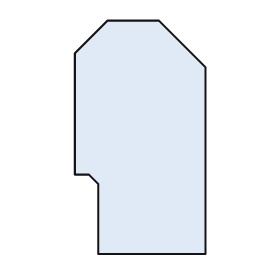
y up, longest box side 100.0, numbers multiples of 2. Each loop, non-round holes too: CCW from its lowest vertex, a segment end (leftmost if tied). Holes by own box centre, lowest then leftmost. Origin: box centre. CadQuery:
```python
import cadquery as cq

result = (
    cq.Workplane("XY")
    .moveTo(-18.0, -50.0)
    .lineTo(28.0, -50.0)
    .lineTo(28.0, 30.0)
    .lineTo(8.0, 50.0)
    .lineTo(-14.0, 50.0)
    .lineTo(-28.0, 36.0)
    .lineTo(-28.0, -16.0)
    .lineTo(-22.0, -16.0)
    .lineTo(-18.0, -20.0)
    .close()
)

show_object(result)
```